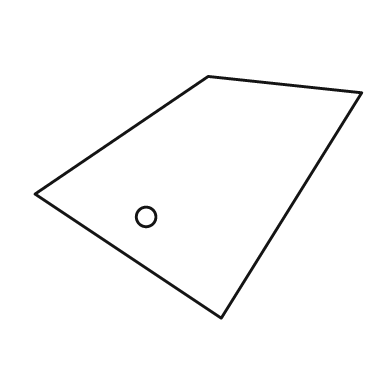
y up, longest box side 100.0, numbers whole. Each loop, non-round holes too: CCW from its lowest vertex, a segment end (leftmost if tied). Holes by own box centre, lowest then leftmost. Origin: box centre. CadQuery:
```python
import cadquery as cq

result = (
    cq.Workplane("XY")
    .moveTo(7.0, -37.0)
    .lineTo(50.0, 32.0)
    .lineTo(3.0, 37.0)
    .lineTo(-50.0, 1.0)
    .close()
    .moveTo(-16.0, -6.0)
    .circle(3.0)
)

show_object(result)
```